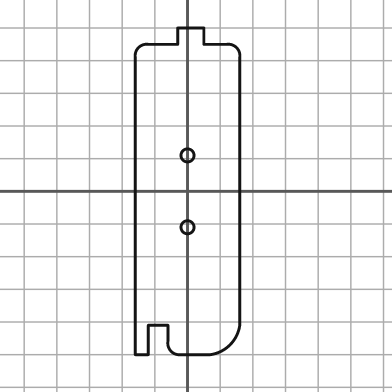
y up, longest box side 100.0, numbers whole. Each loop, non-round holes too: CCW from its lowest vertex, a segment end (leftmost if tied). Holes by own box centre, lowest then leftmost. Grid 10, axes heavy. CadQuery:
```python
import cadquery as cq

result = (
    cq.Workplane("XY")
    .moveTo(-16.0, -50.0)
    .lineTo(-12.0, -50.0)
    .lineTo(-12.0, -41.0)
    .lineTo(-6.0, -41.0)
    .lineTo(-6.0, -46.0)
    .threePointArc((-5.0, -49.0), (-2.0, -50.0))
    .lineTo(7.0, -50.0)
    .threePointArc((13.0, -47.0), (16.0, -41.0))
    .lineTo(16.0, 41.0)
    .threePointArc((15.0, 44.0), (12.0, 45.0))
    .lineTo(5.0, 45.0)
    .lineTo(5.0, 50.0)
    .lineTo(-3.0, 50.0)
    .lineTo(-3.0, 45.0)
    .lineTo(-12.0, 45.0)
    .threePointArc((-15.0, 44.0), (-16.0, 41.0))
    .close()
    .moveTo(0.0, -11.0)
    .circle(2.0)
    .moveTo(0.0, 11.0)
    .circle(2.0)
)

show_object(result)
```